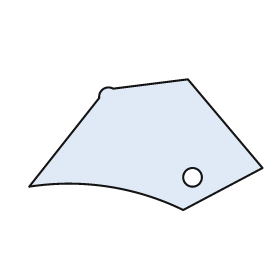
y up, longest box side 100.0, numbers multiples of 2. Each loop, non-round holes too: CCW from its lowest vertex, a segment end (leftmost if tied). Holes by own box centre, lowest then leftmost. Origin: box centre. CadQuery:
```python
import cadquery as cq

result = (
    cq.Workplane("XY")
    .moveTo(16.0, -28.0)
    .lineTo(50.0, -10.0)
    .lineTo(18.0, 28.0)
    .lineTo(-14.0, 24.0)
    .threePointArc((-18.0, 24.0), (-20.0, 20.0))
    .lineTo(-50.0, -18.0)
    .threePointArc((-16.0, -18.0), (16.0, -28.0))
    .close()
    .moveTo(20.0, -14.0)
    .circle(4.0)
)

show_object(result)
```